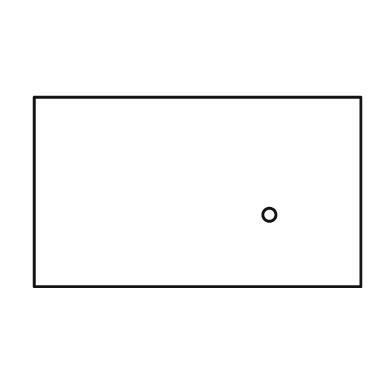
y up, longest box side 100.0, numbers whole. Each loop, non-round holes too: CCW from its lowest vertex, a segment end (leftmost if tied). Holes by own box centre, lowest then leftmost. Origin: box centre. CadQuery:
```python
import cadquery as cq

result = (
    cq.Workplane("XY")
    .moveTo(-50.0, -29.0)
    .lineTo(50.0, -29.0)
    .lineTo(50.0, 29.0)
    .lineTo(-50.0, 29.0)
    .close()
    .moveTo(22.0, -7.0)
    .circle(2.0)
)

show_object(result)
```